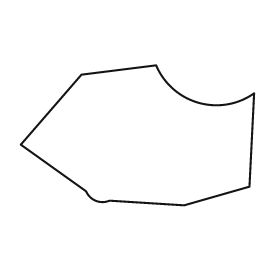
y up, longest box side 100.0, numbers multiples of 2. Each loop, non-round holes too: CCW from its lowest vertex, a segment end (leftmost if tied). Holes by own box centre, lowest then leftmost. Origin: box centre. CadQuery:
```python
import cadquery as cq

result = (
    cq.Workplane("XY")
    .moveTo(20.0, -30.0)
    .lineTo(48.0, -22.0)
    .lineTo(50.0, 18.0)
    .threePointArc((26.0, 14.0), (8.0, 30.0))
    .lineTo(-24.0, 26.0)
    .lineTo(-50.0, -4.0)
    .lineTo(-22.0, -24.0)
    .threePointArc((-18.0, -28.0), (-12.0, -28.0))
    .close()
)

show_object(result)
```